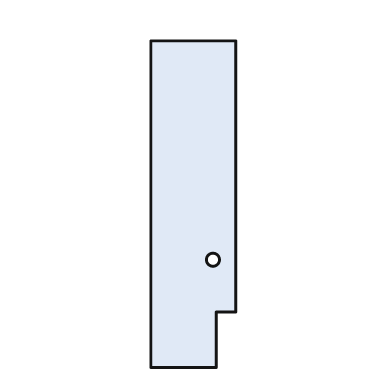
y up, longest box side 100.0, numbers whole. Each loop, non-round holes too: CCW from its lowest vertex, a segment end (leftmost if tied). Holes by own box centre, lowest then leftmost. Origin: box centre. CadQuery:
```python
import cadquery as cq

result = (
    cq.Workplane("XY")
    .moveTo(-13.0, -50.0)
    .lineTo(7.0, -50.0)
    .lineTo(7.0, -33.0)
    .lineTo(13.0, -33.0)
    .lineTo(13.0, 50.0)
    .lineTo(-13.0, 50.0)
    .close()
    .moveTo(6.0, -17.0)
    .circle(2.0)
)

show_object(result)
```